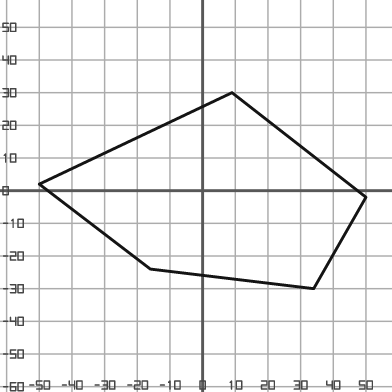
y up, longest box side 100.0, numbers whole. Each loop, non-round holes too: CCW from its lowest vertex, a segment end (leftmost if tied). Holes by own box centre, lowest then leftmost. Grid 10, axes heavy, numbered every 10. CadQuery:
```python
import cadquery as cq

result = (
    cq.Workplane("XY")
    .moveTo(34.0, -30.0)
    .lineTo(50.0, -2.0)
    .lineTo(9.0, 30.0)
    .lineTo(-50.0, 2.0)
    .lineTo(-16.0, -24.0)
    .close()
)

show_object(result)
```